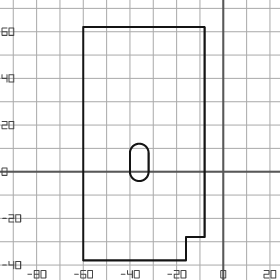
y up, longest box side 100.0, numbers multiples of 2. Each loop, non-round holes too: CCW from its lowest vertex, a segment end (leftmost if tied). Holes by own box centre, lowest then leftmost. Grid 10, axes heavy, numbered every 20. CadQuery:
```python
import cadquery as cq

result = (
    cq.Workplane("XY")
    .moveTo(-60.0, -38.0)
    .lineTo(-16.0, -38.0)
    .lineTo(-16.0, -28.0)
    .lineTo(-8.0, -28.0)
    .lineTo(-8.0, 62.0)
    .lineTo(-60.0, 62.0)
    .close()
    .moveTo(-40.0, 0.0)
    .threePointArc((-36.0, -4.0), (-32.0, 0.0))
    .lineTo(-32.0, 8.0)
    .threePointArc((-36.0, 12.0), (-40.0, 8.0))
    .close()
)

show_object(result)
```